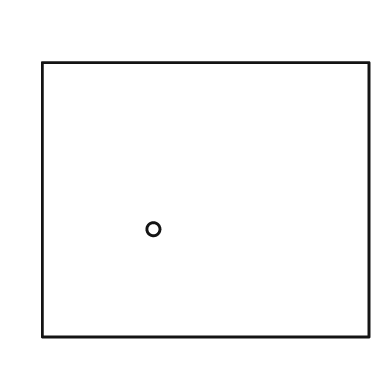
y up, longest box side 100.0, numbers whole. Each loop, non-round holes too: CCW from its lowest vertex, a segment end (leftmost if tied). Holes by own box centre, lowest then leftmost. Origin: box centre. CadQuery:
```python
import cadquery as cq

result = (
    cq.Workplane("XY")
    .moveTo(-50.0, -42.0)
    .lineTo(50.0, -42.0)
    .lineTo(50.0, 42.0)
    .lineTo(-50.0, 42.0)
    .close()
    .moveTo(-16.0, -9.0)
    .circle(2.0)
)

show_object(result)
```